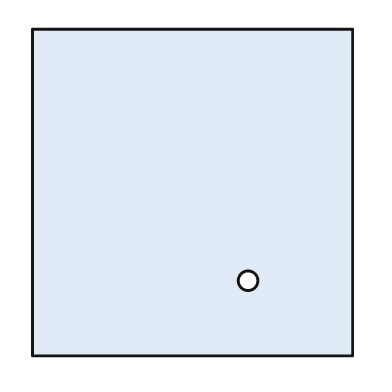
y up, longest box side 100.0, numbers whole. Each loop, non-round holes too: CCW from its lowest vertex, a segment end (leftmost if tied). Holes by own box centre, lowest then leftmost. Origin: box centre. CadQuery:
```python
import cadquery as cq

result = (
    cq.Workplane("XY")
    .moveTo(-49.0, -50.0)
    .lineTo(49.0, -50.0)
    .lineTo(49.0, 50.0)
    .lineTo(-49.0, 50.0)
    .close()
    .moveTo(17.0, -27.0)
    .circle(3.0)
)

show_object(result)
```